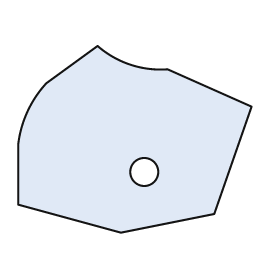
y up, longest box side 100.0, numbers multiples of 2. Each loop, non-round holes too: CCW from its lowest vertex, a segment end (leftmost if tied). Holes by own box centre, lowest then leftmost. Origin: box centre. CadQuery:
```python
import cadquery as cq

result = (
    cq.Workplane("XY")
    .moveTo(-6.0, -40.0)
    .lineTo(34.0, -32.0)
    .lineTo(50.0, 14.0)
    .lineTo(14.0, 30.0)
    .threePointArc((-2.0, 32.0), (-16.0, 40.0))
    .lineTo(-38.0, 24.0)
    .threePointArc((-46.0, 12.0), (-50.0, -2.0))
    .lineTo(-50.0, -28.0)
    .close()
    .moveTo(4.0, -14.0)
    .circle(6.0)
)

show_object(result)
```